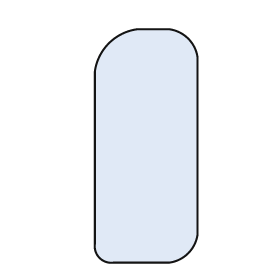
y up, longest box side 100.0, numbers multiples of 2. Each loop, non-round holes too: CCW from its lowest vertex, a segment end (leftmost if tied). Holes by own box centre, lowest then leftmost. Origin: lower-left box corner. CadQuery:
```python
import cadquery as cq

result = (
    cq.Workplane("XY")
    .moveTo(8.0, 0.0)
    .lineTo(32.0, 0.0)
    .threePointArc((40.0, 4.0), (44.0, 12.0))
    .lineTo(44.0, 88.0)
    .threePointArc((40.0, 96.0), (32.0, 100.0))
    .lineTo(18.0, 100.0)
    .threePointArc((6.0, 94.0), (0.0, 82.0))
    .lineTo(0.0, 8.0)
    .threePointArc((2.0, 2.0), (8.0, 0.0))
    .close()
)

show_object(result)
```